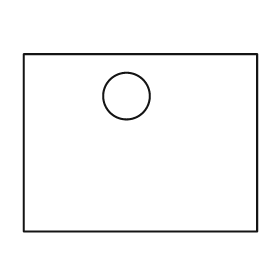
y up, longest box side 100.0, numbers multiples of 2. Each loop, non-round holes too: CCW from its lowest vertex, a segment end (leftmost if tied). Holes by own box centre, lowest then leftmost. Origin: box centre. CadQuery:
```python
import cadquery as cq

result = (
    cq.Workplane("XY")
    .moveTo(-50.0, -38.0)
    .lineTo(50.0, -38.0)
    .lineTo(50.0, 38.0)
    .lineTo(-50.0, 38.0)
    .close()
    .moveTo(-6.0, 20.0)
    .circle(10.0)
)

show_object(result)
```